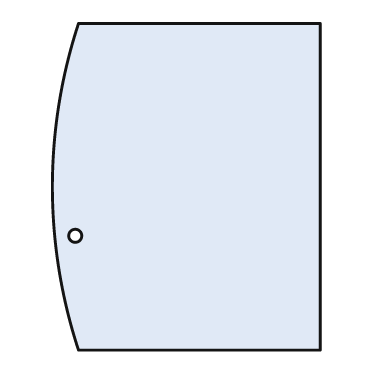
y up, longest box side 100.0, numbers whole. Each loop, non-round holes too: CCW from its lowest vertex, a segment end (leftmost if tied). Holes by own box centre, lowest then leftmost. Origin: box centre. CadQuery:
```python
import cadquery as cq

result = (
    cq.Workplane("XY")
    .moveTo(-33.0, -50.0)
    .lineTo(41.0, -50.0)
    .lineTo(41.0, 50.0)
    .lineTo(-33.0, 50.0)
    .threePointArc((-41.0, 0.0), (-33.0, -50.0))
    .close()
    .moveTo(-34.0, -15.0)
    .circle(2.0)
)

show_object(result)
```